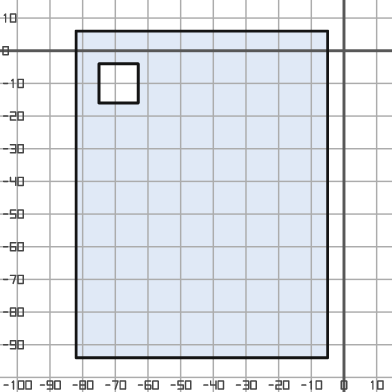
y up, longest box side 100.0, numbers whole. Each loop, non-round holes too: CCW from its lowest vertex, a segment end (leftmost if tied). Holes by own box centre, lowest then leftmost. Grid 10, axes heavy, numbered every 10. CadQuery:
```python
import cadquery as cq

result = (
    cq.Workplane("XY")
    .moveTo(-82.0, -94.0)
    .lineTo(-5.0, -94.0)
    .lineTo(-5.0, 6.0)
    .lineTo(-82.0, 6.0)
    .close()
    .moveTo(-75.0, -16.0)
    .lineTo(-63.0, -16.0)
    .lineTo(-63.0, -4.0)
    .lineTo(-75.0, -4.0)
    .close()
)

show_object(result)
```